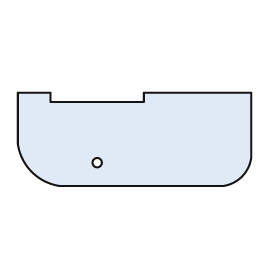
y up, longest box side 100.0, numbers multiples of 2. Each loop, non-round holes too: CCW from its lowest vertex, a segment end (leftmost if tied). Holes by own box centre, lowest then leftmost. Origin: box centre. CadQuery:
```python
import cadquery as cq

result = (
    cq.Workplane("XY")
    .moveTo(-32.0, -20.0)
    .lineTo(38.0, -20.0)
    .threePointArc((46.0, -16.0), (50.0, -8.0))
    .lineTo(50.0, 20.0)
    .lineTo(4.0, 20.0)
    .lineTo(4.0, 16.0)
    .lineTo(-36.0, 16.0)
    .lineTo(-36.0, 20.0)
    .lineTo(-50.0, 20.0)
    .lineTo(-50.0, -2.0)
    .threePointArc((-44.0, -14.0), (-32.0, -20.0))
    .close()
    .moveTo(-16.0, -10.0)
    .circle(2.0)
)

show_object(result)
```